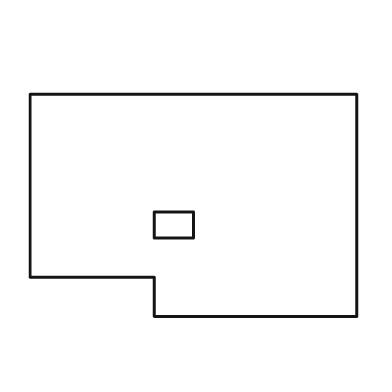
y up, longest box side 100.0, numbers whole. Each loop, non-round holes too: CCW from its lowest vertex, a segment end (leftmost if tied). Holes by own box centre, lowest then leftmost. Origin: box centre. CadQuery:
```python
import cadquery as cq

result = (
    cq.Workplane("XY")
    .moveTo(-12.0, -34.0)
    .lineTo(50.0, -34.0)
    .lineTo(50.0, 34.0)
    .lineTo(-50.0, 34.0)
    .lineTo(-50.0, -22.0)
    .lineTo(-12.0, -22.0)
    .close()
    .moveTo(-12.0, -10.0)
    .lineTo(0.0, -10.0)
    .lineTo(0.0, -2.0)
    .lineTo(-12.0, -2.0)
    .close()
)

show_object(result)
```